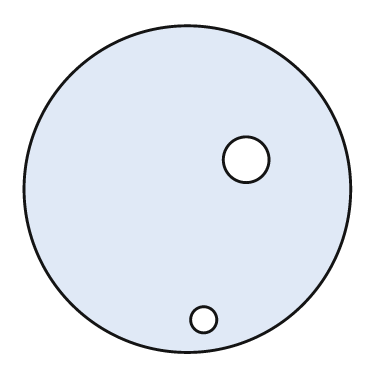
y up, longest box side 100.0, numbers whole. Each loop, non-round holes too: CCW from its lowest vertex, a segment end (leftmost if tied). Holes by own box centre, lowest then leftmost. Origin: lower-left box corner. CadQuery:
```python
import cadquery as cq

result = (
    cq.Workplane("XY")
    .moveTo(50.0, 50.0)
    .circle(50.0)
    .moveTo(55.0, 10.0)
    .circle(4.0)
    .moveTo(68.0, 59.0)
    .circle(7.0)
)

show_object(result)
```